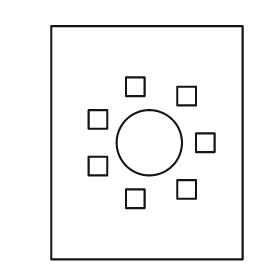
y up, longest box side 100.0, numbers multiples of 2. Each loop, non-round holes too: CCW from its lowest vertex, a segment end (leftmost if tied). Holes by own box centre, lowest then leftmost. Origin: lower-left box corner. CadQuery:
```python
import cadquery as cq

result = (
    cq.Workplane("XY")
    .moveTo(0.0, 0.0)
    .lineTo(82.0, 0.0)
    .lineTo(82.0, 100.0)
    .lineTo(0.0, 100.0)
    .close()
    .moveTo(32.0, 22.0)
    .lineTo(40.0, 22.0)
    .lineTo(40.0, 30.0)
    .lineTo(32.0, 30.0)
    .close()
    .moveTo(54.0, 26.0)
    .lineTo(62.0, 26.0)
    .lineTo(62.0, 34.0)
    .lineTo(54.0, 34.0)
    .close()
    .moveTo(16.0, 36.0)
    .lineTo(24.0, 36.0)
    .lineTo(24.0, 44.0)
    .lineTo(16.0, 44.0)
    .close()
    .moveTo(42.0, 50.0)
    .circle(14.0)
    .moveTo(62.0, 46.0)
    .lineTo(70.0, 46.0)
    .lineTo(70.0, 54.0)
    .lineTo(62.0, 54.0)
    .close()
    .moveTo(16.0, 56.0)
    .lineTo(24.0, 56.0)
    .lineTo(24.0, 64.0)
    .lineTo(16.0, 64.0)
    .close()
    .moveTo(54.0, 66.0)
    .lineTo(62.0, 66.0)
    .lineTo(62.0, 74.0)
    .lineTo(54.0, 74.0)
    .close()
    .moveTo(32.0, 70.0)
    .lineTo(40.0, 70.0)
    .lineTo(40.0, 78.0)
    .lineTo(32.0, 78.0)
    .close()
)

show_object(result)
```